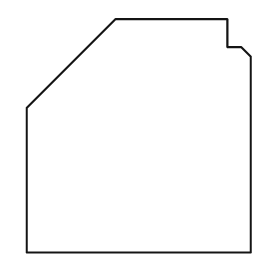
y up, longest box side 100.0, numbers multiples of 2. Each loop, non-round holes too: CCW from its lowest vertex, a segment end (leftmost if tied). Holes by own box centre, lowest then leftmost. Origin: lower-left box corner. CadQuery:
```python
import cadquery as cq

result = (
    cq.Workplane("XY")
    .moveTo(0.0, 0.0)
    .lineTo(96.0, 0.0)
    .lineTo(96.0, 84.0)
    .lineTo(92.0, 88.0)
    .lineTo(86.0, 88.0)
    .lineTo(86.0, 100.0)
    .lineTo(38.0, 100.0)
    .lineTo(0.0, 62.0)
    .close()
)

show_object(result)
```